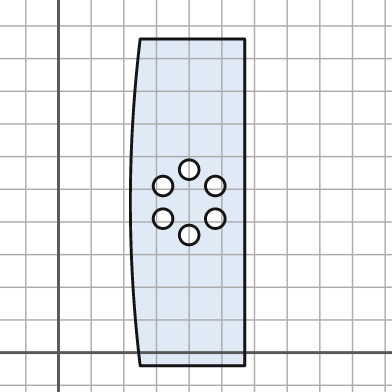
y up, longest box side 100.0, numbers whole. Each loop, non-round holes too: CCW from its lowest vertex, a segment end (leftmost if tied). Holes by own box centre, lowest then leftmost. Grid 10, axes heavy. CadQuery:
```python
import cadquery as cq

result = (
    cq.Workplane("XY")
    .moveTo(25.0, -4.0)
    .lineTo(57.0, -4.0)
    .lineTo(57.0, 96.0)
    .lineTo(25.0, 96.0)
    .threePointArc((22.0, 46.0), (25.0, -4.0))
    .close()
    .moveTo(40.0, 36.0)
    .circle(3.0)
    .moveTo(32.0, 41.0)
    .circle(3.0)
    .moveTo(48.0, 41.0)
    .circle(3.0)
    .moveTo(32.0, 51.0)
    .circle(3.0)
    .moveTo(48.0, 51.0)
    .circle(3.0)
    .moveTo(40.0, 56.0)
    .circle(3.0)
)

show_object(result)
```